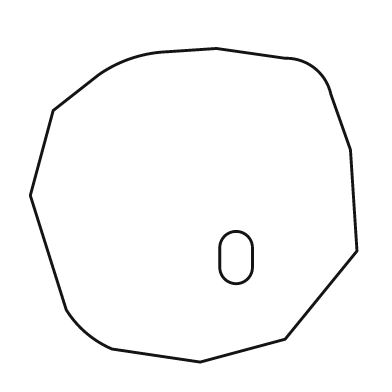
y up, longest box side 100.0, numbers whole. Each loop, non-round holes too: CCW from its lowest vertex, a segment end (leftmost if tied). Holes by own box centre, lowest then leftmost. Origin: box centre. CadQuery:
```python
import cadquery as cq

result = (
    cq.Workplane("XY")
    .moveTo(2.0, -48.0)
    .lineTo(28.0, -41.0)
    .lineTo(50.0, -14.0)
    .lineTo(48.0, 17.0)
    .lineTo(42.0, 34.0)
    .threePointArc((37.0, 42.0), (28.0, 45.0))
    .lineTo(7.0, 48.0)
    .lineTo(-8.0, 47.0)
    .threePointArc((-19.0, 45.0), (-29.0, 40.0))
    .lineTo(-43.0, 29.0)
    .lineTo(-50.0, 3.0)
    .lineTo(-39.0, -32.0)
    .threePointArc((-33.0, -39.0), (-25.0, -44.0))
    .close()
    .moveTo(8.0, -19.0)
    .threePointArc((13.0, -24.0), (18.0, -19.0))
    .lineTo(18.0, -13.0)
    .threePointArc((13.0, -8.0), (8.0, -13.0))
    .close()
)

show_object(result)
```